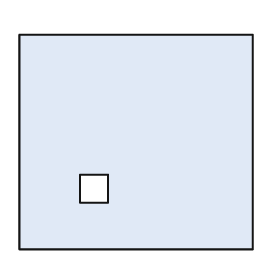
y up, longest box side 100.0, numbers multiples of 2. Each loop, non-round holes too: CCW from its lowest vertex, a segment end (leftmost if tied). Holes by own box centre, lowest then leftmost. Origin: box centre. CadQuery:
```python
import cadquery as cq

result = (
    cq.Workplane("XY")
    .moveTo(-50.0, -46.0)
    .lineTo(50.0, -46.0)
    .lineTo(50.0, 46.0)
    .lineTo(-50.0, 46.0)
    .close()
    .moveTo(-24.0, -26.0)
    .lineTo(-12.0, -26.0)
    .lineTo(-12.0, -14.0)
    .lineTo(-24.0, -14.0)
    .close()
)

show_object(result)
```